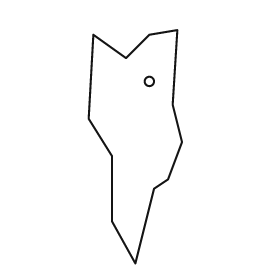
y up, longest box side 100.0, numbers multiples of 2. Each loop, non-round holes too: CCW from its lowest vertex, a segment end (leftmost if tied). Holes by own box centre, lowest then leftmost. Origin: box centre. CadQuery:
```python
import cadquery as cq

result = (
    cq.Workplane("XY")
    .moveTo(0.0, -50.0)
    .lineTo(8.0, -18.0)
    .lineTo(14.0, -14.0)
    .lineTo(20.0, 2.0)
    .lineTo(16.0, 18.0)
    .lineTo(18.0, 50.0)
    .lineTo(6.0, 48.0)
    .lineTo(-4.0, 38.0)
    .lineTo(-18.0, 48.0)
    .lineTo(-20.0, 12.0)
    .lineTo(-10.0, -4.0)
    .lineTo(-10.0, -32.0)
    .close()
    .moveTo(6.0, 28.0)
    .circle(2.0)
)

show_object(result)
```